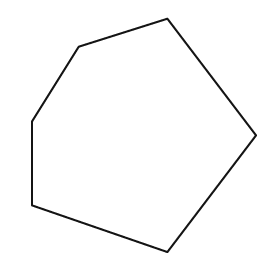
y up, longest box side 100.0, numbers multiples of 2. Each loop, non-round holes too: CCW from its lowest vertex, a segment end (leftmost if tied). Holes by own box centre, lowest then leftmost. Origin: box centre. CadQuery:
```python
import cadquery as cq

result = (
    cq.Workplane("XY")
    .moveTo(10.0, -50.0)
    .lineTo(48.0, 0.0)
    .lineTo(10.0, 50.0)
    .lineTo(-28.0, 38.0)
    .lineTo(-48.0, 6.0)
    .lineTo(-48.0, -30.0)
    .close()
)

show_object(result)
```